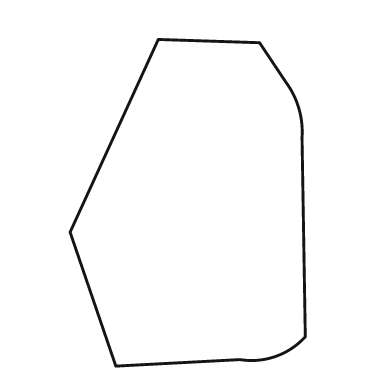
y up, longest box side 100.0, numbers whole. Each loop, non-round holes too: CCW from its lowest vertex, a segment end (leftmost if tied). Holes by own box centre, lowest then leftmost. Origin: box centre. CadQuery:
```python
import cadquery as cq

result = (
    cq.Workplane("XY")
    .moveTo(-22.0, -50.0)
    .lineTo(16.0, -48.0)
    .threePointArc((27.0, -47.0), (36.0, -41.0))
    .lineTo(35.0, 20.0)
    .threePointArc((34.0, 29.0), (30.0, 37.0))
    .lineTo(22.0, 49.0)
    .lineTo(-9.0, 50.0)
    .lineTo(-36.0, -9.0)
    .close()
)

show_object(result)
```